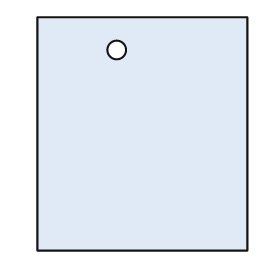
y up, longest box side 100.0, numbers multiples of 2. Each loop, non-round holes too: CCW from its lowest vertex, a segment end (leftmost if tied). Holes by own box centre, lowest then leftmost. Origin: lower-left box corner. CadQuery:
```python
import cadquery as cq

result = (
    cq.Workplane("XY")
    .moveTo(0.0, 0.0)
    .lineTo(90.0, 0.0)
    .lineTo(90.0, 100.0)
    .lineTo(0.0, 100.0)
    .close()
    .moveTo(34.0, 86.0)
    .circle(4.0)
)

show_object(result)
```